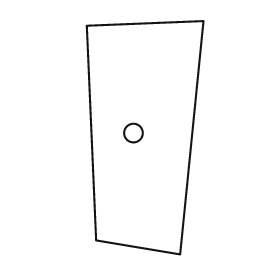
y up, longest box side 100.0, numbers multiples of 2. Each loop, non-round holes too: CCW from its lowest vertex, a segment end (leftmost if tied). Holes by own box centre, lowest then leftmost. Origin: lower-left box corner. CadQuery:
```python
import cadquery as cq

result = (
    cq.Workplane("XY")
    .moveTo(40.0, 0.0)
    .lineTo(50.0, 100.0)
    .lineTo(0.0, 98.0)
    .lineTo(4.0, 6.0)
    .close()
    .moveTo(20.0, 52.0)
    .circle(4.0)
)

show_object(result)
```